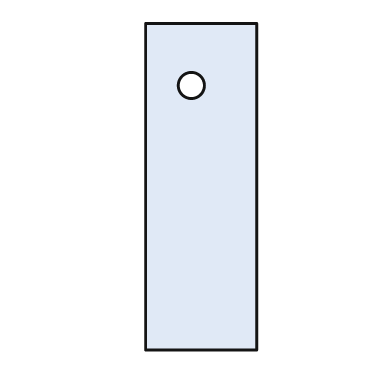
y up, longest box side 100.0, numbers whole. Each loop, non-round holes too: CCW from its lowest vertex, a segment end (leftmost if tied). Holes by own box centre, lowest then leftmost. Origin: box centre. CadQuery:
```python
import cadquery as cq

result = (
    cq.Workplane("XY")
    .moveTo(-17.0, -50.0)
    .lineTo(17.0, -50.0)
    .lineTo(17.0, 50.0)
    .lineTo(-17.0, 50.0)
    .close()
    .moveTo(-3.0, 31.0)
    .circle(4.0)
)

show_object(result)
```